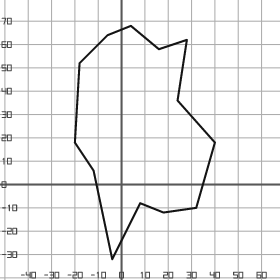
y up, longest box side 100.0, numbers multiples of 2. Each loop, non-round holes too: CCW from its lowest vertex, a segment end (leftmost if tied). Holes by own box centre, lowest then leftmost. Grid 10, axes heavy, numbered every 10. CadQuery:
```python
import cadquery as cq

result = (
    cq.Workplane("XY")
    .moveTo(-4.0, -32.0)
    .lineTo(8.0, -8.0)
    .lineTo(18.0, -12.0)
    .lineTo(32.0, -10.0)
    .lineTo(40.0, 18.0)
    .lineTo(24.0, 36.0)
    .lineTo(28.0, 62.0)
    .lineTo(16.0, 58.0)
    .lineTo(4.0, 68.0)
    .lineTo(-6.0, 64.0)
    .lineTo(-18.0, 52.0)
    .lineTo(-20.0, 18.0)
    .lineTo(-12.0, 6.0)
    .close()
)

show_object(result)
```